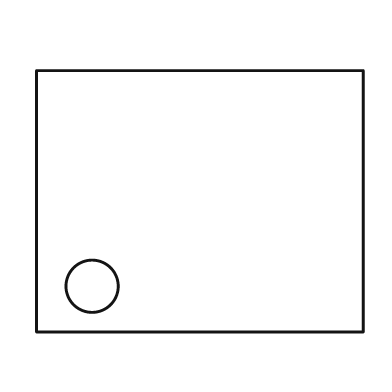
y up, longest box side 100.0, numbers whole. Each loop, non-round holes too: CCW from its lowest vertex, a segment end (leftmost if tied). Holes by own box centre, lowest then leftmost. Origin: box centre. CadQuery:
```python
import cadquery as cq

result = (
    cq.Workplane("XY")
    .moveTo(-50.0, -40.0)
    .lineTo(50.0, -40.0)
    .lineTo(50.0, 40.0)
    .lineTo(-50.0, 40.0)
    .close()
    .moveTo(-33.0, -26.0)
    .circle(8.0)
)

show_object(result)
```